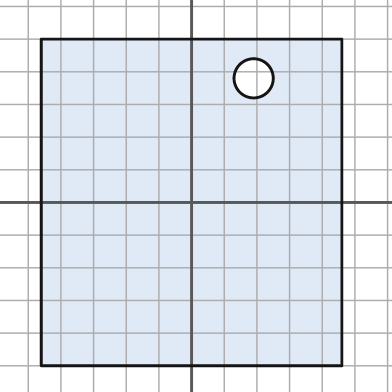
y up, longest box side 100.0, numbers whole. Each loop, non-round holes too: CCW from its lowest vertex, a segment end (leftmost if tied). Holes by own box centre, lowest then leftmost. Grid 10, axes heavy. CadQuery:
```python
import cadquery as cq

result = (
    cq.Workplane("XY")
    .moveTo(-46.0, -50.0)
    .lineTo(46.0, -50.0)
    .lineTo(46.0, 50.0)
    .lineTo(-46.0, 50.0)
    .close()
    .moveTo(19.0, 38.0)
    .circle(6.0)
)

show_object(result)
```